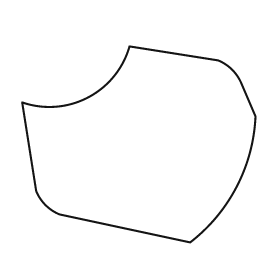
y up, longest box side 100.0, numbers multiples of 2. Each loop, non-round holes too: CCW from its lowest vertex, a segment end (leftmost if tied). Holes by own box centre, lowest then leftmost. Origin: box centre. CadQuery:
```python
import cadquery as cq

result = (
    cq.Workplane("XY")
    .moveTo(22.0, -42.0)
    .threePointArc((42.0, -18.0), (50.0, 12.0))
    .lineTo(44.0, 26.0)
    .threePointArc((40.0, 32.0), (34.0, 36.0))
    .lineTo(-4.0, 42.0)
    .threePointArc((-22.0, 20.0), (-50.0, 18.0))
    .lineTo(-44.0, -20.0)
    .threePointArc((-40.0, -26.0), (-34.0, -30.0))
    .close()
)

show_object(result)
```